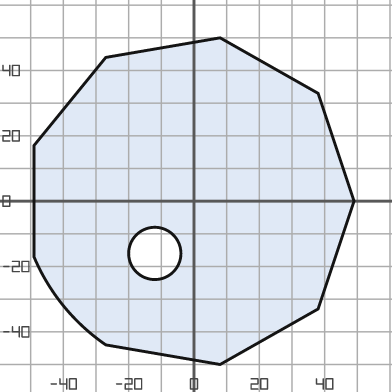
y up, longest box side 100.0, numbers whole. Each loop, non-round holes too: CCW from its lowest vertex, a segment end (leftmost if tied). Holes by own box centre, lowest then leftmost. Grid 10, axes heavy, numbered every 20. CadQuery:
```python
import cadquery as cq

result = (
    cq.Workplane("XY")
    .moveTo(8.0, -50.0)
    .lineTo(38.0, -33.0)
    .lineTo(49.0, 0.0)
    .lineTo(38.0, 33.0)
    .lineTo(8.0, 50.0)
    .lineTo(-27.0, 44.0)
    .lineTo(-49.0, 17.0)
    .lineTo(-49.0, -17.0)
    .threePointArc((-40.0, -32.0), (-27.0, -44.0))
    .close()
    .moveTo(-12.0, -16.0)
    .circle(8.0)
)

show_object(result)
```